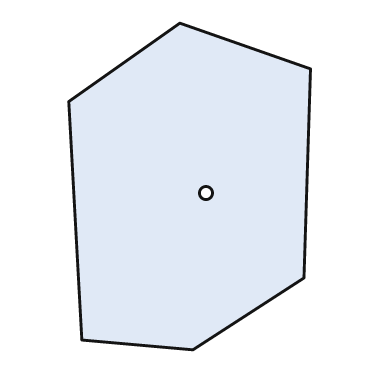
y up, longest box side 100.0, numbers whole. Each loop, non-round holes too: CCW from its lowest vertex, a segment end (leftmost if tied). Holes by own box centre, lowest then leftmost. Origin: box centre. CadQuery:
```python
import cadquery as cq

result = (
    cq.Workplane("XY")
    .moveTo(1.0, -50.0)
    .lineTo(35.0, -28.0)
    .lineTo(37.0, 36.0)
    .lineTo(-3.0, 50.0)
    .lineTo(-37.0, 26.0)
    .lineTo(-33.0, -47.0)
    .close()
    .moveTo(5.0, -2.0)
    .circle(2.0)
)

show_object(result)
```